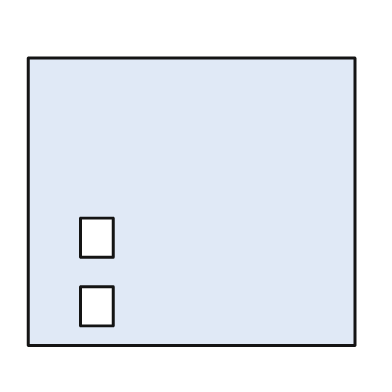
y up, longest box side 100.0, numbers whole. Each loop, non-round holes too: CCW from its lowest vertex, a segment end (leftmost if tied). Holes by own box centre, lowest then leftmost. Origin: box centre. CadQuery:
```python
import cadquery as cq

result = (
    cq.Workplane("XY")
    .moveTo(-50.0, -44.0)
    .lineTo(50.0, -44.0)
    .lineTo(50.0, 44.0)
    .lineTo(-50.0, 44.0)
    .close()
    .moveTo(-34.0, -38.0)
    .lineTo(-24.0, -38.0)
    .lineTo(-24.0, -26.0)
    .lineTo(-34.0, -26.0)
    .close()
    .moveTo(-34.0, -17.0)
    .lineTo(-24.0, -17.0)
    .lineTo(-24.0, -5.0)
    .lineTo(-34.0, -5.0)
    .close()
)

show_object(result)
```